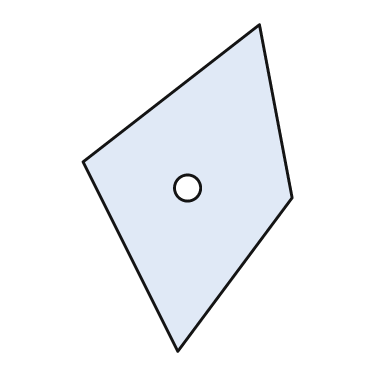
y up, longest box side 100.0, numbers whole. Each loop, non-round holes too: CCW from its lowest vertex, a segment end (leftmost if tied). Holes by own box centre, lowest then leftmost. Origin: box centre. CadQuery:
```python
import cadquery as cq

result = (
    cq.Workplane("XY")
    .moveTo(-3.0, -50.0)
    .lineTo(32.0, -3.0)
    .lineTo(22.0, 50.0)
    .lineTo(-32.0, 8.0)
    .close()
    .moveTo(0.0, 0.0)
    .circle(4.0)
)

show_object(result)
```